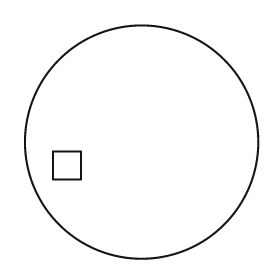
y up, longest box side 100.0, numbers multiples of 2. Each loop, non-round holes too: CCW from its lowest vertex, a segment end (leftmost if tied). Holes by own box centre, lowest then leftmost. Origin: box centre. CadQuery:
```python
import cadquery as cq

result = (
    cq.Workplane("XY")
    .moveTo(0.0, 0.0)
    .circle(50.0)
    .moveTo(-38.0, -16.0)
    .lineTo(-26.0, -16.0)
    .lineTo(-26.0, -4.0)
    .lineTo(-38.0, -4.0)
    .close()
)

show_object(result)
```